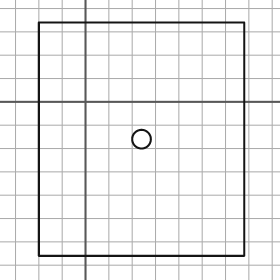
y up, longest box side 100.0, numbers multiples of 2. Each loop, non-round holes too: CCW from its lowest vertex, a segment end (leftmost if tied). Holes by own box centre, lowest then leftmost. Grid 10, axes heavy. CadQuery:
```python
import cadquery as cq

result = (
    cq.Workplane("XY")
    .moveTo(-20.0, -66.0)
    .lineTo(68.0, -66.0)
    .lineTo(68.0, 34.0)
    .lineTo(-20.0, 34.0)
    .close()
    .moveTo(24.0, -16.0)
    .circle(4.0)
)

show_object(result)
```